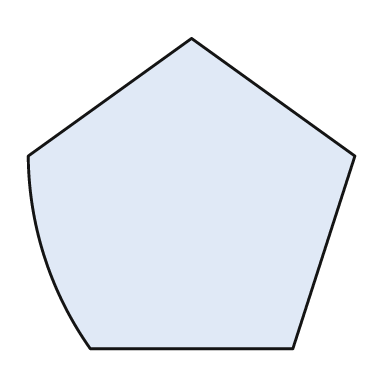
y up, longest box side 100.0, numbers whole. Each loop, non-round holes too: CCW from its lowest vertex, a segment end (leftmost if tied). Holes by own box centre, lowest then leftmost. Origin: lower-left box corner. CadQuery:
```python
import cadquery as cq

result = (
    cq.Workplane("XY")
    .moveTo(19.0, 0.0)
    .lineTo(81.0, 0.0)
    .lineTo(100.0, 59.0)
    .lineTo(50.0, 95.0)
    .lineTo(0.0, 59.0)
    .threePointArc((5.0, 28.0), (19.0, 0.0))
    .close()
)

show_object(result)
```